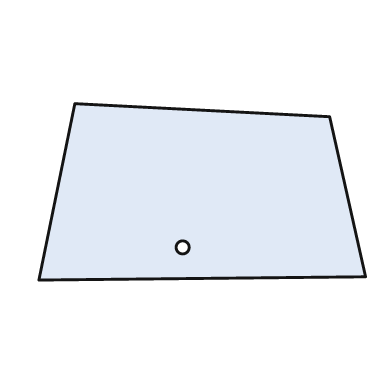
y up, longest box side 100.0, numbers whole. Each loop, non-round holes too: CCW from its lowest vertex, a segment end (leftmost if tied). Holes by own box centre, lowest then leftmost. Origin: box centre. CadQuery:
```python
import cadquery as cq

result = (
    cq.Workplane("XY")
    .moveTo(-50.0, -27.0)
    .lineTo(50.0, -26.0)
    .lineTo(39.0, 23.0)
    .lineTo(-39.0, 27.0)
    .close()
    .moveTo(-6.0, -17.0)
    .circle(2.0)
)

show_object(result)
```